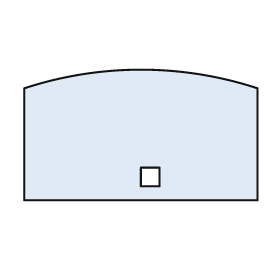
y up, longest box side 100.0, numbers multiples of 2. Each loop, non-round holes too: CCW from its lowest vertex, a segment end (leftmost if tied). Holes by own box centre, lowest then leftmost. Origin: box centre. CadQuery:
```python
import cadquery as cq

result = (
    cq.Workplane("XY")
    .moveTo(-50.0, -28.0)
    .lineTo(50.0, -28.0)
    .lineTo(50.0, 20.0)
    .threePointArc((0.0, 28.0), (-50.0, 20.0))
    .close()
    .moveTo(0.0, -22.0)
    .lineTo(8.0, -22.0)
    .lineTo(8.0, -14.0)
    .lineTo(0.0, -14.0)
    .close()
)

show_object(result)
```